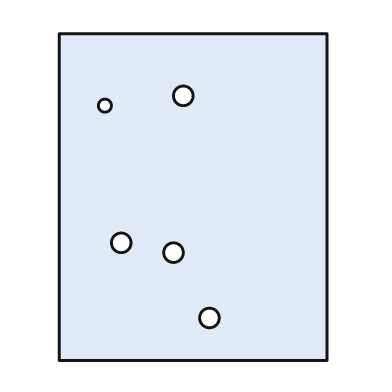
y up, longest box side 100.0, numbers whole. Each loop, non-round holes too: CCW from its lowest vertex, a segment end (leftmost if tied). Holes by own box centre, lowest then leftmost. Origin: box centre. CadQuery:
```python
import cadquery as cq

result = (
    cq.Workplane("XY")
    .moveTo(-41.0, -50.0)
    .lineTo(41.0, -50.0)
    .lineTo(41.0, 50.0)
    .lineTo(-41.0, 50.0)
    .close()
    .moveTo(5.0, -37.0)
    .circle(3.0)
    .moveTo(-6.0, -17.0)
    .circle(3.0)
    .moveTo(-22.0, -14.0)
    .circle(3.0)
    .moveTo(-27.0, 28.0)
    .circle(2.0)
    .moveTo(-3.0, 31.0)
    .circle(3.0)
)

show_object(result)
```